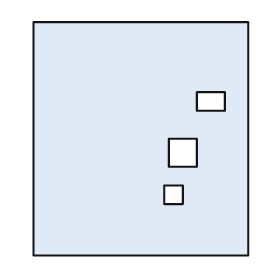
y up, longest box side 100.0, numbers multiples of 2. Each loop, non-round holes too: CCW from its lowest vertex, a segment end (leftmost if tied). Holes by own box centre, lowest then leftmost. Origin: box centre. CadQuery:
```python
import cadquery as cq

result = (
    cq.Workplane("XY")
    .moveTo(-46.0, -50.0)
    .lineTo(46.0, -50.0)
    .lineTo(46.0, 50.0)
    .lineTo(-46.0, 50.0)
    .close()
    .moveTo(10.0, -28.0)
    .lineTo(18.0, -28.0)
    .lineTo(18.0, -20.0)
    .lineTo(10.0, -20.0)
    .close()
    .moveTo(12.0, -12.0)
    .lineTo(24.0, -12.0)
    .lineTo(24.0, 0.0)
    .lineTo(12.0, 0.0)
    .close()
    .moveTo(24.0, 12.0)
    .lineTo(36.0, 12.0)
    .lineTo(36.0, 20.0)
    .lineTo(24.0, 20.0)
    .close()
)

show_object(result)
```